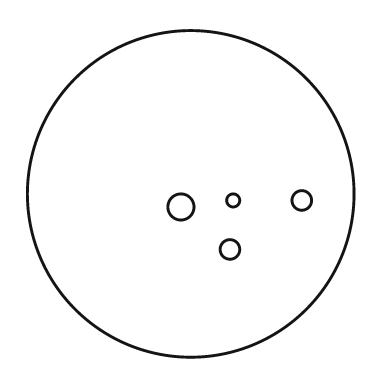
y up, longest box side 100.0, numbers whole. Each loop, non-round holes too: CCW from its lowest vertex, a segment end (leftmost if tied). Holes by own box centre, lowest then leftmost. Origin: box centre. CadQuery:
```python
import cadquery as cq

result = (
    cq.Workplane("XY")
    .moveTo(0.0, 0.0)
    .circle(50.0)
    .moveTo(12.0, -17.0)
    .circle(3.0)
    .moveTo(-3.0, -4.0)
    .circle(4.0)
    .moveTo(13.0, -2.0)
    .circle(2.0)
    .moveTo(34.0, -2.0)
    .circle(3.0)
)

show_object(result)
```